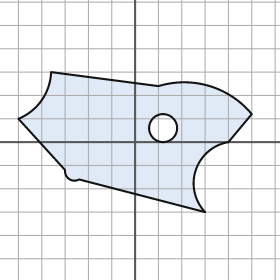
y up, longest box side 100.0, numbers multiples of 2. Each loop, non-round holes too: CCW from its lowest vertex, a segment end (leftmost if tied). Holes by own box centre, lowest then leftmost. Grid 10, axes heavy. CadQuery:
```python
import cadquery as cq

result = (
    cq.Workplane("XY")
    .moveTo(30.0, -30.0)
    .threePointArc((26.0, -12.0), (40.0, 0.0))
    .lineTo(50.0, 12.0)
    .threePointArc((32.0, 24.0), (10.0, 24.0))
    .lineTo(-36.0, 30.0)
    .threePointArc((-40.0, 18.0), (-50.0, 10.0))
    .lineTo(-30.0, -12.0)
    .threePointArc((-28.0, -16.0), (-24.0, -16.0))
    .close()
    .moveTo(12.0, 6.0)
    .circle(6.0)
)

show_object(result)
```